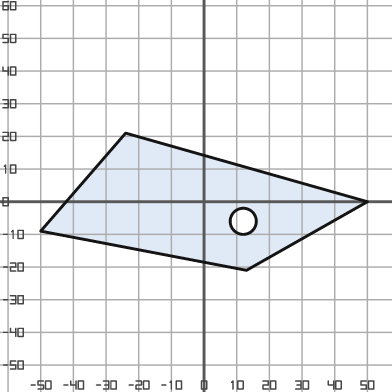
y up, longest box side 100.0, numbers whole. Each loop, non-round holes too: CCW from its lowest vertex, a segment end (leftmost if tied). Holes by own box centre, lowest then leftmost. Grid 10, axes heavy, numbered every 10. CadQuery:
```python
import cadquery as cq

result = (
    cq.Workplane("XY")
    .moveTo(13.0, -21.0)
    .lineTo(50.0, 0.0)
    .lineTo(-24.0, 21.0)
    .lineTo(-50.0, -9.0)
    .close()
    .moveTo(12.0, -6.0)
    .circle(4.0)
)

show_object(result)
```